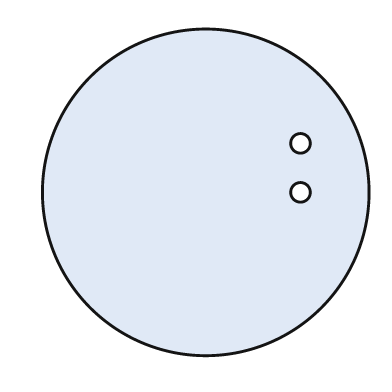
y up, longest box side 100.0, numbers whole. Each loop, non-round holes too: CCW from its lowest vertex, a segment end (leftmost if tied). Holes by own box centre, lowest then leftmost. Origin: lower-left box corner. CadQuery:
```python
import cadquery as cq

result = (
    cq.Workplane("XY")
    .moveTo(50.0, 50.0)
    .circle(50.0)
    .moveTo(79.0, 50.0)
    .circle(3.0)
    .moveTo(79.0, 65.0)
    .circle(3.0)
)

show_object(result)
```